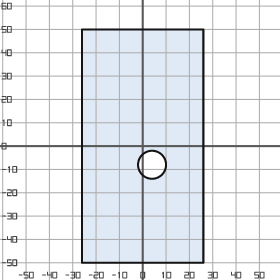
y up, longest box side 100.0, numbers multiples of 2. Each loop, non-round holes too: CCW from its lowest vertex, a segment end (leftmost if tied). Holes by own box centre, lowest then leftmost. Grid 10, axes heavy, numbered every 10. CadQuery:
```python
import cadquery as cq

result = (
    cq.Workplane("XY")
    .moveTo(-26.0, -50.0)
    .lineTo(26.0, -50.0)
    .lineTo(26.0, 50.0)
    .lineTo(-26.0, 50.0)
    .close()
    .moveTo(4.0, -8.0)
    .circle(6.0)
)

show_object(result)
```